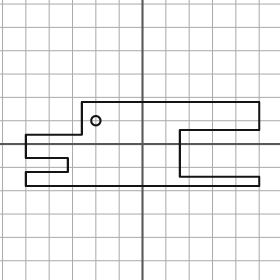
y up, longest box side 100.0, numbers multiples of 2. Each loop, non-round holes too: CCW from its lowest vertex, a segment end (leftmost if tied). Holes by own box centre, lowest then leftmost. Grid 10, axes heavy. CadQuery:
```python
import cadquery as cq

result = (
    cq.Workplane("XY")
    .moveTo(-50.0, -18.0)
    .lineTo(50.0, -18.0)
    .lineTo(50.0, -14.0)
    .lineTo(16.0, -14.0)
    .lineTo(16.0, 6.0)
    .lineTo(50.0, 6.0)
    .lineTo(50.0, 18.0)
    .lineTo(-26.0, 18.0)
    .lineTo(-26.0, 4.0)
    .lineTo(-50.0, 4.0)
    .lineTo(-50.0, -6.0)
    .lineTo(-32.0, -6.0)
    .lineTo(-32.0, -12.0)
    .lineTo(-50.0, -12.0)
    .close()
    .moveTo(-20.0, 10.0)
    .circle(2.0)
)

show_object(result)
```